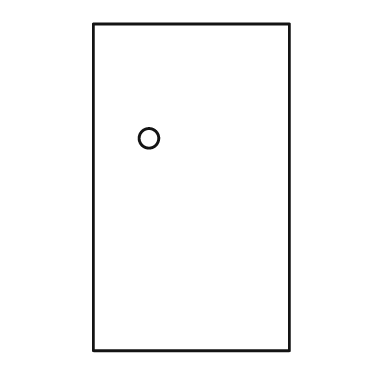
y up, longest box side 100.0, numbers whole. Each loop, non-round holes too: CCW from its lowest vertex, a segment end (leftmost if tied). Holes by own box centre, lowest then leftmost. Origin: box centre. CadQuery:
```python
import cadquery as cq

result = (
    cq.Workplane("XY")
    .moveTo(-30.0, -50.0)
    .lineTo(30.0, -50.0)
    .lineTo(30.0, 50.0)
    .lineTo(-30.0, 50.0)
    .close()
    .moveTo(-13.0, 15.0)
    .circle(3.0)
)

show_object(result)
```